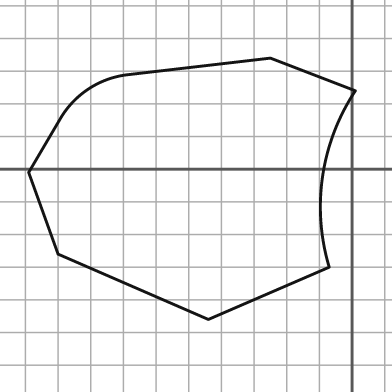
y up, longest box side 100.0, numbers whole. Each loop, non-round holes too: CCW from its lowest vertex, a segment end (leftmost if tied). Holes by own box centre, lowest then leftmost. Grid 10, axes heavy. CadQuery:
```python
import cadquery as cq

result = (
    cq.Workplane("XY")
    .moveTo(-44.0, -46.0)
    .lineTo(-7.0, -30.0)
    .threePointArc((-9.0, -2.0), (1.0, 24.0))
    .lineTo(-25.0, 34.0)
    .lineTo(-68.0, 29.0)
    .threePointArc((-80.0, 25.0), (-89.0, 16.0))
    .lineTo(-99.0, -1.0)
    .lineTo(-90.0, -26.0)
    .close()
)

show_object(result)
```